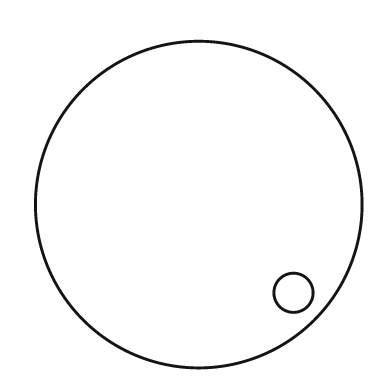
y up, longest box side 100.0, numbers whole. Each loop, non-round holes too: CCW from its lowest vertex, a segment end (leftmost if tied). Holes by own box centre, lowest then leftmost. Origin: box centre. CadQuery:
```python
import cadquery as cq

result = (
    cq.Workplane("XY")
    .moveTo(0.0, 0.0)
    .circle(50.0)
    .moveTo(29.0, -27.0)
    .circle(6.0)
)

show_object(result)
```